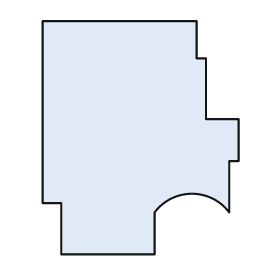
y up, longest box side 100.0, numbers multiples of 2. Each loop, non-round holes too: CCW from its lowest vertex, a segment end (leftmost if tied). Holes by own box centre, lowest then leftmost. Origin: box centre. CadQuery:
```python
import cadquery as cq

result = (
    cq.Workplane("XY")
    .moveTo(-34.0, -50.0)
    .lineTo(6.0, -50.0)
    .lineTo(6.0, -32.0)
    .threePointArc((22.0, -24.0), (38.0, -32.0))
    .lineTo(38.0, -10.0)
    .lineTo(42.0, -10.0)
    .lineTo(42.0, 8.0)
    .lineTo(28.0, 8.0)
    .lineTo(28.0, 34.0)
    .lineTo(24.0, 34.0)
    .lineTo(24.0, 50.0)
    .lineTo(-42.0, 50.0)
    .lineTo(-42.0, -28.0)
    .lineTo(-34.0, -28.0)
    .close()
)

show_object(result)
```